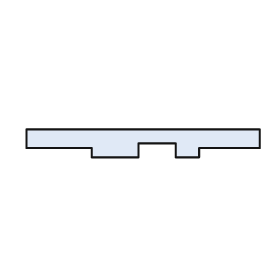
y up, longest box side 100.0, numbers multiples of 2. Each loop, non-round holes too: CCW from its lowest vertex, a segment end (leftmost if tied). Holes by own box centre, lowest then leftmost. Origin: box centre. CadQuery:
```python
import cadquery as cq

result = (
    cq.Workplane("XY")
    .moveTo(-22.0, -6.0)
    .lineTo(-2.0, -6.0)
    .lineTo(-2.0, 0.0)
    .lineTo(14.0, 0.0)
    .lineTo(14.0, -6.0)
    .lineTo(24.0, -6.0)
    .lineTo(24.0, -2.0)
    .lineTo(50.0, -2.0)
    .lineTo(50.0, 6.0)
    .lineTo(-50.0, 6.0)
    .lineTo(-50.0, -2.0)
    .lineTo(-22.0, -2.0)
    .close()
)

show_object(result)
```